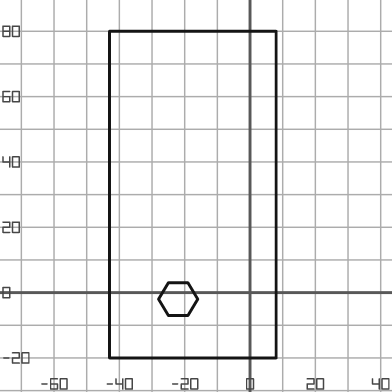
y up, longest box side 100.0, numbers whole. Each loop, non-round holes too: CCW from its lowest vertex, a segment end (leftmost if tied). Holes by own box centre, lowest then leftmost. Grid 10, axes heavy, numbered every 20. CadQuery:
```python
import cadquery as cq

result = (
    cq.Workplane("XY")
    .moveTo(-43.0, -20.0)
    .lineTo(8.0, -20.0)
    .lineTo(8.0, 80.0)
    .lineTo(-43.0, 80.0)
    .close()
    .moveTo(-25.0, -7.0)
    .lineTo(-19.0, -7.0)
    .lineTo(-16.0, -2.0)
    .lineTo(-19.0, 3.0)
    .lineTo(-25.0, 3.0)
    .lineTo(-28.0, -2.0)
    .close()
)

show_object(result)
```